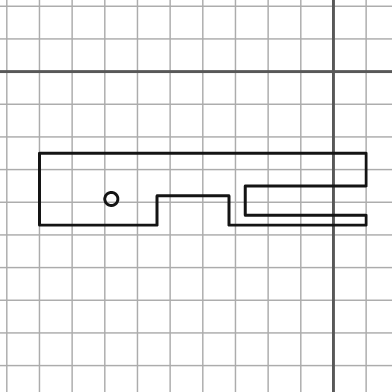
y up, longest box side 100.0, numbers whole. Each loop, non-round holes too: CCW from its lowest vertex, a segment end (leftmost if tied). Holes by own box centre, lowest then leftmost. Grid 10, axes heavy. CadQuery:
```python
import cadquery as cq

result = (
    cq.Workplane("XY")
    .moveTo(-90.0, -47.0)
    .lineTo(-54.0, -47.0)
    .lineTo(-54.0, -38.0)
    .lineTo(-32.0, -38.0)
    .lineTo(-32.0, -47.0)
    .lineTo(10.0, -47.0)
    .lineTo(10.0, -44.0)
    .lineTo(-27.0, -44.0)
    .lineTo(-27.0, -35.0)
    .lineTo(10.0, -35.0)
    .lineTo(10.0, -25.0)
    .lineTo(-90.0, -25.0)
    .close()
    .moveTo(-68.0, -39.0)
    .circle(2.0)
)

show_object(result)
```